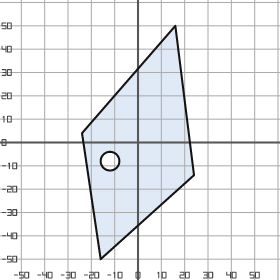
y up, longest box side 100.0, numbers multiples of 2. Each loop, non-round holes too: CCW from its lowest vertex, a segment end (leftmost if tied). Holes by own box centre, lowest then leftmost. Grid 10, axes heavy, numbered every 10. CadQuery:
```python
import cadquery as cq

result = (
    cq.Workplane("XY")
    .moveTo(-16.0, -50.0)
    .lineTo(24.0, -14.0)
    .lineTo(16.0, 50.0)
    .lineTo(-24.0, 4.0)
    .close()
    .moveTo(-12.0, -8.0)
    .circle(4.0)
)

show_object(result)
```